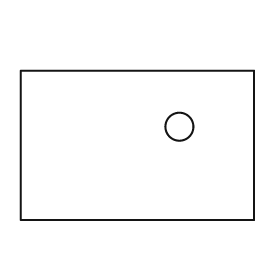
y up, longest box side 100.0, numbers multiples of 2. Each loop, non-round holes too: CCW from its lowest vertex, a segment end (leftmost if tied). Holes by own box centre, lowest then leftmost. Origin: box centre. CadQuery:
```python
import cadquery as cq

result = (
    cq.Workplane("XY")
    .moveTo(-50.0, -32.0)
    .lineTo(50.0, -32.0)
    .lineTo(50.0, 32.0)
    .lineTo(-50.0, 32.0)
    .close()
    .moveTo(18.0, 8.0)
    .circle(6.0)
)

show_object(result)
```